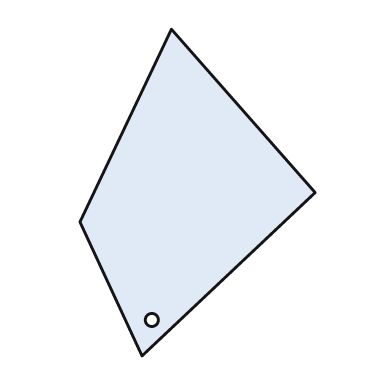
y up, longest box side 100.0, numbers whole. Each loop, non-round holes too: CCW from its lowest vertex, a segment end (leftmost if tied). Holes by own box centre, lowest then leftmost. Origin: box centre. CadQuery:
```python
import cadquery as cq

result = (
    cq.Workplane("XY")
    .moveTo(-17.0, -50.0)
    .lineTo(36.0, 0.0)
    .lineTo(-8.0, 50.0)
    .lineTo(-36.0, -9.0)
    .close()
    .moveTo(-14.0, -39.0)
    .circle(2.0)
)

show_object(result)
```